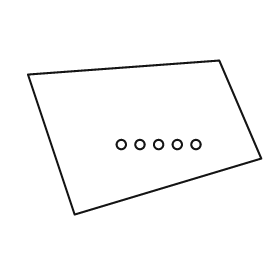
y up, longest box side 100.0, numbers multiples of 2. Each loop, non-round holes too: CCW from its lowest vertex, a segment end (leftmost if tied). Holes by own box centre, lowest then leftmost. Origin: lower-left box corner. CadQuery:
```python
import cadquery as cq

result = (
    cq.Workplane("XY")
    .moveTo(20.0, 0.0)
    .lineTo(100.0, 24.0)
    .lineTo(82.0, 66.0)
    .lineTo(0.0, 60.0)
    .close()
    .moveTo(40.0, 30.0)
    .circle(2.0)
    .moveTo(48.0, 30.0)
    .circle(2.0)
    .moveTo(56.0, 30.0)
    .circle(2.0)
    .moveTo(64.0, 30.0)
    .circle(2.0)
    .moveTo(72.0, 30.0)
    .circle(2.0)
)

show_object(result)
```